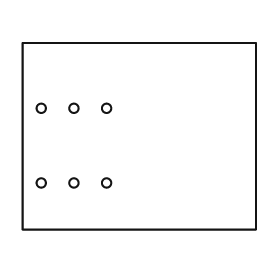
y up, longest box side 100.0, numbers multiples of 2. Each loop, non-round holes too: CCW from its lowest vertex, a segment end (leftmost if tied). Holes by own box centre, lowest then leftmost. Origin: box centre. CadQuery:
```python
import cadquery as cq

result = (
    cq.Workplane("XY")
    .moveTo(-50.0, -40.0)
    .lineTo(50.0, -40.0)
    .lineTo(50.0, 40.0)
    .lineTo(-50.0, 40.0)
    .close()
    .moveTo(-42.0, -20.0)
    .circle(2.0)
    .moveTo(-28.0, -20.0)
    .circle(2.0)
    .moveTo(-14.0, -20.0)
    .circle(2.0)
    .moveTo(-42.0, 12.0)
    .circle(2.0)
    .moveTo(-28.0, 12.0)
    .circle(2.0)
    .moveTo(-14.0, 12.0)
    .circle(2.0)
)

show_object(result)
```